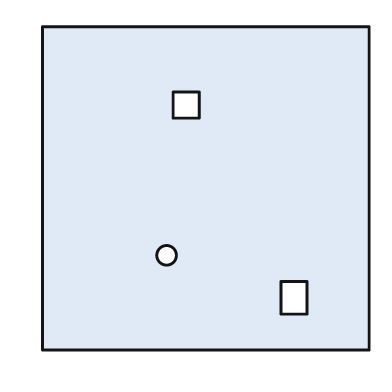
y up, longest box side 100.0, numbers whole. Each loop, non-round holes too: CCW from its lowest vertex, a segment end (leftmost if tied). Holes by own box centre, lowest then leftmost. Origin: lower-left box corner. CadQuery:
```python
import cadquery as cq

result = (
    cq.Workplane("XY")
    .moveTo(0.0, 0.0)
    .lineTo(100.0, 0.0)
    .lineTo(100.0, 99.0)
    .lineTo(0.0, 99.0)
    .close()
    .moveTo(73.0, 11.0)
    .lineTo(81.0, 11.0)
    .lineTo(81.0, 21.0)
    .lineTo(73.0, 21.0)
    .close()
    .moveTo(38.0, 29.0)
    .circle(3.0)
    .moveTo(40.0, 71.0)
    .lineTo(48.0, 71.0)
    .lineTo(48.0, 79.0)
    .lineTo(40.0, 79.0)
    .close()
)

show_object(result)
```